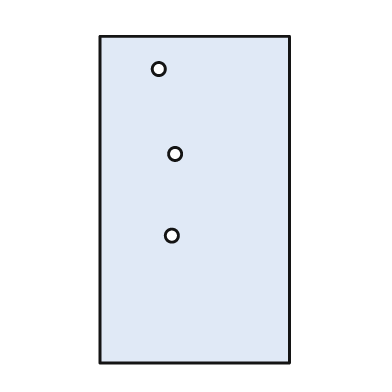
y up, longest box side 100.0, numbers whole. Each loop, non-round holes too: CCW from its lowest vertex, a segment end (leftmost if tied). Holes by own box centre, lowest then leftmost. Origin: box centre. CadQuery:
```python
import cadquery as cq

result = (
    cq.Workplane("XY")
    .moveTo(-29.0, -50.0)
    .lineTo(29.0, -50.0)
    .lineTo(29.0, 50.0)
    .lineTo(-29.0, 50.0)
    .close()
    .moveTo(-7.0, -11.0)
    .circle(2.0)
    .moveTo(-6.0, 14.0)
    .circle(2.0)
    .moveTo(-11.0, 40.0)
    .circle(2.0)
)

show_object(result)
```